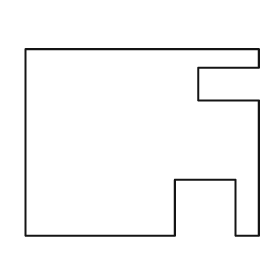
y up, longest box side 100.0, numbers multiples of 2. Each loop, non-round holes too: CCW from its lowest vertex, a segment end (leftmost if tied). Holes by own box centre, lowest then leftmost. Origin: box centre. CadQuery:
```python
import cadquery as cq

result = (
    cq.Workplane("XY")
    .moveTo(-50.0, -40.0)
    .lineTo(14.0, -40.0)
    .lineTo(14.0, -16.0)
    .lineTo(40.0, -16.0)
    .lineTo(40.0, -40.0)
    .lineTo(50.0, -40.0)
    .lineTo(50.0, 18.0)
    .lineTo(24.0, 18.0)
    .lineTo(24.0, 32.0)
    .lineTo(50.0, 32.0)
    .lineTo(50.0, 40.0)
    .lineTo(-50.0, 40.0)
    .close()
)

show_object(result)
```